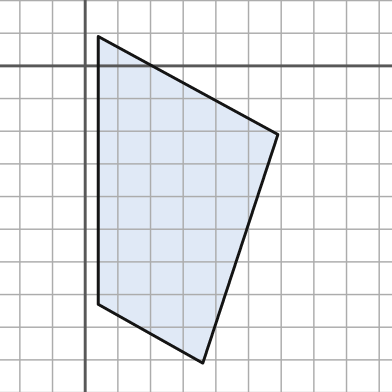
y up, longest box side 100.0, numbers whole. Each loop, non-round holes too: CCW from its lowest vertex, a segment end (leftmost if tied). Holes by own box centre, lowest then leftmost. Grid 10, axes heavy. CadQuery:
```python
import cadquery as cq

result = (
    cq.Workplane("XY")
    .moveTo(36.0, -91.0)
    .lineTo(59.0, -21.0)
    .lineTo(4.0, 9.0)
    .lineTo(4.0, -73.0)
    .close()
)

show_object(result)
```